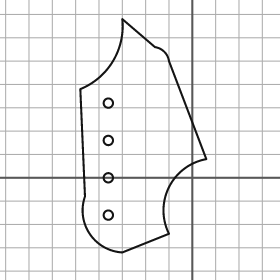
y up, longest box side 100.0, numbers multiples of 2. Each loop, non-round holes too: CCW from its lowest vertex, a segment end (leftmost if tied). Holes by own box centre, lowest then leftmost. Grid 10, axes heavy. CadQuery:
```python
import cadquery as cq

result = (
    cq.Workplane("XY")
    .moveTo(-30.0, -32.0)
    .lineTo(-10.0, -24.0)
    .threePointArc((-10.0, -4.0), (6.0, 8.0))
    .lineTo(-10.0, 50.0)
    .threePointArc((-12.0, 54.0), (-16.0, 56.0))
    .lineTo(-30.0, 68.0)
    .threePointArc((-34.0, 50.0), (-48.0, 38.0))
    .lineTo(-46.0, -8.0)
    .threePointArc((-44.0, -24.0), (-30.0, -32.0))
    .close()
    .moveTo(-36.0, -16.0)
    .circle(2.0)
    .moveTo(-36.0, 0.0)
    .circle(2.0)
    .moveTo(-36.0, 16.0)
    .circle(2.0)
    .moveTo(-36.0, 32.0)
    .circle(2.0)
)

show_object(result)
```